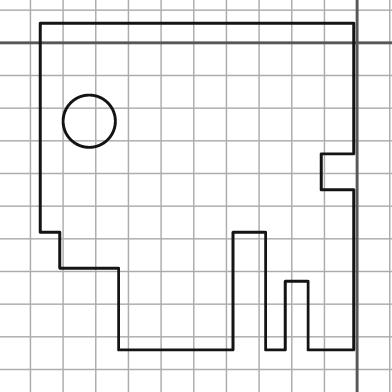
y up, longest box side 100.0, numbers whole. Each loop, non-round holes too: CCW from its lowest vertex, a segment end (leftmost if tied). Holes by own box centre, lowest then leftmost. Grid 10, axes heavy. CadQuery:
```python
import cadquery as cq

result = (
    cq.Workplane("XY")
    .moveTo(-73.0, -94.0)
    .lineTo(-38.0, -94.0)
    .lineTo(-38.0, -58.0)
    .lineTo(-28.0, -58.0)
    .lineTo(-28.0, -94.0)
    .lineTo(-22.0, -94.0)
    .lineTo(-22.0, -73.0)
    .lineTo(-15.0, -73.0)
    .lineTo(-15.0, -94.0)
    .lineTo(-1.0, -94.0)
    .lineTo(-1.0, -45.0)
    .lineTo(-11.0, -45.0)
    .lineTo(-11.0, -34.0)
    .lineTo(-1.0, -34.0)
    .lineTo(-1.0, 6.0)
    .lineTo(-97.0, 6.0)
    .lineTo(-97.0, -58.0)
    .lineTo(-91.0, -58.0)
    .lineTo(-91.0, -69.0)
    .lineTo(-73.0, -69.0)
    .close()
    .moveTo(-82.0, -24.0)
    .circle(8.0)
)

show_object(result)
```